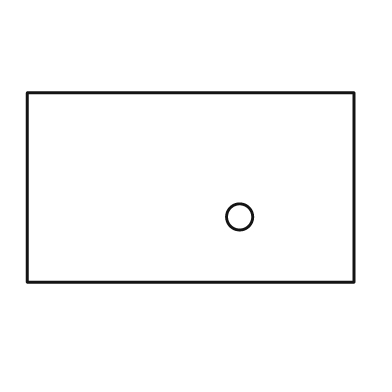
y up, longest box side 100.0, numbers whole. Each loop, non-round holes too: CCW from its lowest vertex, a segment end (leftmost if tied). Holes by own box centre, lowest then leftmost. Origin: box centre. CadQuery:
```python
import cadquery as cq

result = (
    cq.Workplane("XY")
    .moveTo(-50.0, -29.0)
    .lineTo(50.0, -29.0)
    .lineTo(50.0, 29.0)
    .lineTo(-50.0, 29.0)
    .close()
    .moveTo(15.0, -9.0)
    .circle(4.0)
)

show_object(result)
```